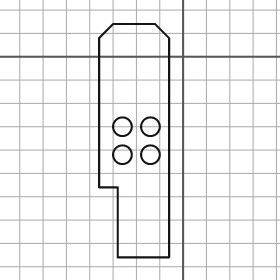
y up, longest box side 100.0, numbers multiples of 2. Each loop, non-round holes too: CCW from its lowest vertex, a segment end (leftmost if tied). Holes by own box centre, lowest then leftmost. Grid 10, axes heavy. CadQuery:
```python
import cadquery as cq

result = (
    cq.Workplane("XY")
    .moveTo(-28.0, -86.0)
    .lineTo(-6.0, -86.0)
    .lineTo(-6.0, 8.0)
    .lineTo(-12.0, 14.0)
    .lineTo(-30.0, 14.0)
    .lineTo(-36.0, 8.0)
    .lineTo(-36.0, -56.0)
    .lineTo(-28.0, -56.0)
    .close()
    .moveTo(-26.0, -42.0)
    .circle(4.0)
    .moveTo(-14.0, -42.0)
    .circle(4.0)
    .moveTo(-26.0, -30.0)
    .circle(4.0)
    .moveTo(-14.0, -30.0)
    .circle(4.0)
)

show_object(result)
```